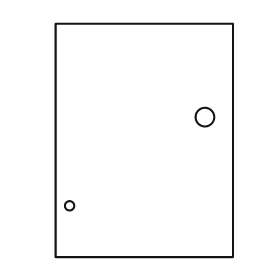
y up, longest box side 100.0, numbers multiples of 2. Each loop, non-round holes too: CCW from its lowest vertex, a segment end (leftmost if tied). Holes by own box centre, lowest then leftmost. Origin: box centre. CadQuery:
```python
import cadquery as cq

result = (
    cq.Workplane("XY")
    .moveTo(-38.0, -50.0)
    .lineTo(38.0, -50.0)
    .lineTo(38.0, 50.0)
    .lineTo(-38.0, 50.0)
    .close()
    .moveTo(-32.0, -28.0)
    .circle(2.0)
    .moveTo(26.0, 10.0)
    .circle(4.0)
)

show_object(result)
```